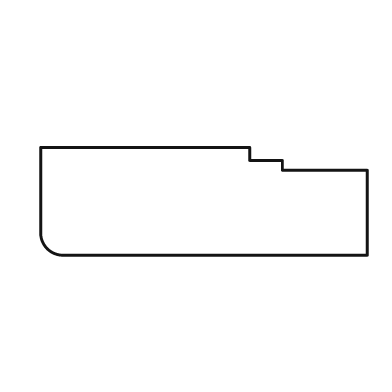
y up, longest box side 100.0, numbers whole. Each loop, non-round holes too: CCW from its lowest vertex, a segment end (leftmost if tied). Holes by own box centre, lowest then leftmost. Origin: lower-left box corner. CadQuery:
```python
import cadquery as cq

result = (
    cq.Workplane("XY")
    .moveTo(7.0, 0.0)
    .lineTo(100.0, 0.0)
    .lineTo(100.0, 26.0)
    .lineTo(74.0, 26.0)
    .lineTo(74.0, 29.0)
    .lineTo(64.0, 29.0)
    .lineTo(64.0, 33.0)
    .lineTo(0.0, 33.0)
    .lineTo(0.0, 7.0)
    .threePointArc((2.0, 2.0), (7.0, 0.0))
    .close()
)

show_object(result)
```